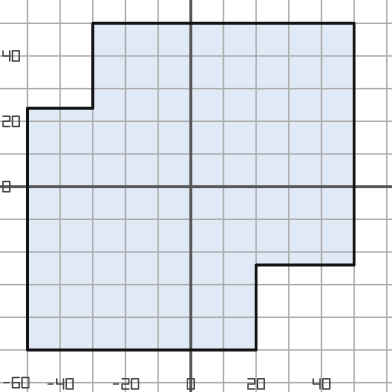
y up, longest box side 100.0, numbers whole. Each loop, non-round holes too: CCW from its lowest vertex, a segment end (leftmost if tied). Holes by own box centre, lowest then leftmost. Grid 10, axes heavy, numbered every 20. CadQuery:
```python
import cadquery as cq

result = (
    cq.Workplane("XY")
    .moveTo(-50.0, -50.0)
    .lineTo(20.0, -50.0)
    .lineTo(20.0, -24.0)
    .lineTo(50.0, -24.0)
    .lineTo(50.0, 50.0)
    .lineTo(-30.0, 50.0)
    .lineTo(-30.0, 24.0)
    .lineTo(-50.0, 24.0)
    .close()
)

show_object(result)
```